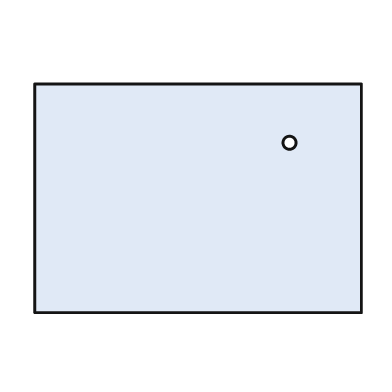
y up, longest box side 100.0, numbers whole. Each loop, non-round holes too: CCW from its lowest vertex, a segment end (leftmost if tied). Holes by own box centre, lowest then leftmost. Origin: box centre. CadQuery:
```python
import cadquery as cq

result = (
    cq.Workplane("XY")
    .moveTo(-50.0, -35.0)
    .lineTo(50.0, -35.0)
    .lineTo(50.0, 35.0)
    .lineTo(-50.0, 35.0)
    .close()
    .moveTo(28.0, 17.0)
    .circle(2.0)
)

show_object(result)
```